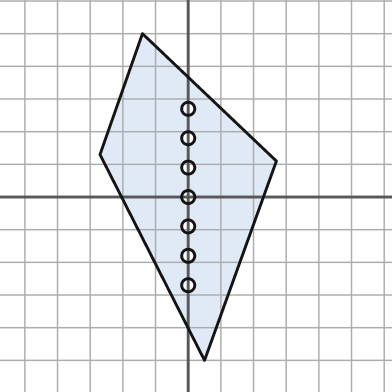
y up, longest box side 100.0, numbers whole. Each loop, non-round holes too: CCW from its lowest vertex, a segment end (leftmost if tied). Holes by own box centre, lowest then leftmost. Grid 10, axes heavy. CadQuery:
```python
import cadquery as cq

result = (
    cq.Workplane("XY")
    .moveTo(5.0, -50.0)
    .lineTo(27.0, 11.0)
    .lineTo(-14.0, 50.0)
    .lineTo(-27.0, 13.0)
    .close()
    .moveTo(0.0, -27.0)
    .circle(2.0)
    .moveTo(0.0, -18.0)
    .circle(2.0)
    .moveTo(0.0, -9.0)
    .circle(2.0)
    .moveTo(0.0, 0.0)
    .circle(2.0)
    .moveTo(0.0, 9.0)
    .circle(2.0)
    .moveTo(0.0, 18.0)
    .circle(2.0)
    .moveTo(0.0, 27.0)
    .circle(2.0)
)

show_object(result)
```